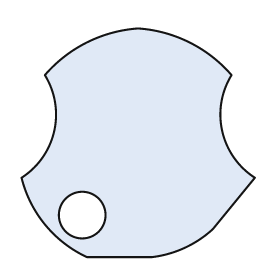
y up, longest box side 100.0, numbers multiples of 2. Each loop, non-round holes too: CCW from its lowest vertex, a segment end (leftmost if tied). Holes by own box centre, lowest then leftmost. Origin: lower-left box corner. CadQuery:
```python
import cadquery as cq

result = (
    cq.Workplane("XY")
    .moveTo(28.0, 0.0)
    .lineTo(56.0, 0.0)
    .threePointArc((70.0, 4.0), (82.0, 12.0))
    .lineTo(100.0, 34.0)
    .threePointArc((86.0, 54.0), (90.0, 78.0))
    .threePointArc((72.0, 92.0), (50.0, 98.0))
    .threePointArc((28.0, 92.0), (10.0, 78.0))
    .threePointArc((14.0, 54.0), (0.0, 34.0))
    .threePointArc((10.0, 14.0), (28.0, 0.0))
    .close()
    .moveTo(26.0, 18.0)
    .circle(10.0)
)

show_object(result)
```